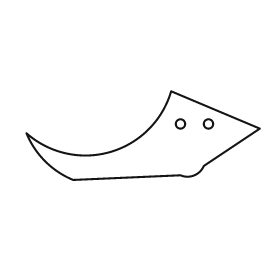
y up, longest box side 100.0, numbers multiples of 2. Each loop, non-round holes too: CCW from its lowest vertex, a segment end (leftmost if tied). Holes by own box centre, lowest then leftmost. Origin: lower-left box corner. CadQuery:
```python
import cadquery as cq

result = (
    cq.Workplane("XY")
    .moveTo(20.0, 0.0)
    .lineTo(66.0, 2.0)
    .threePointArc((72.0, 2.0), (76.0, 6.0))
    .lineTo(100.0, 22.0)
    .lineTo(62.0, 38.0)
    .threePointArc((36.0, 12.0), (0.0, 20.0))
    .threePointArc((8.0, 8.0), (20.0, 0.0))
    .close()
    .moveTo(66.0, 24.0)
    .circle(2.0)
    .moveTo(78.0, 24.0)
    .circle(2.0)
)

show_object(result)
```